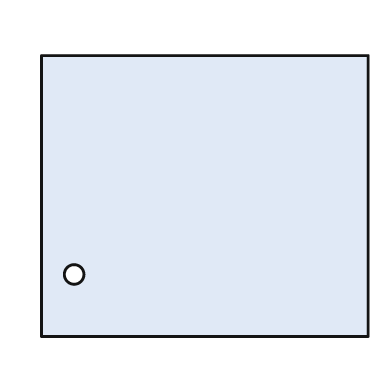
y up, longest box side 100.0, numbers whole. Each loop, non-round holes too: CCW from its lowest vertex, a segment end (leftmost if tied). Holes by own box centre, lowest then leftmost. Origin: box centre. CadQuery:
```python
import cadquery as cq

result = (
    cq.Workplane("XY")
    .moveTo(-50.0, -43.0)
    .lineTo(50.0, -43.0)
    .lineTo(50.0, 43.0)
    .lineTo(-50.0, 43.0)
    .close()
    .moveTo(-40.0, -24.0)
    .circle(3.0)
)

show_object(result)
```